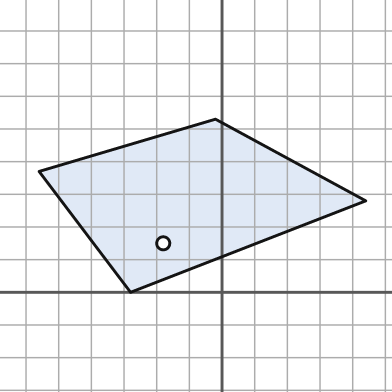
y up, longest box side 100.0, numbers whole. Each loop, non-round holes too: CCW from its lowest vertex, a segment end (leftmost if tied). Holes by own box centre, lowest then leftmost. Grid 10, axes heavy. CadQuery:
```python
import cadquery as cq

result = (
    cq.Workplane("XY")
    .moveTo(-28.0, 0.0)
    .lineTo(44.0, 28.0)
    .lineTo(-2.0, 53.0)
    .lineTo(-56.0, 37.0)
    .close()
    .moveTo(-18.0, 15.0)
    .circle(2.0)
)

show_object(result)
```